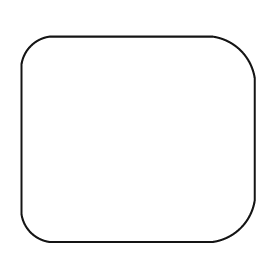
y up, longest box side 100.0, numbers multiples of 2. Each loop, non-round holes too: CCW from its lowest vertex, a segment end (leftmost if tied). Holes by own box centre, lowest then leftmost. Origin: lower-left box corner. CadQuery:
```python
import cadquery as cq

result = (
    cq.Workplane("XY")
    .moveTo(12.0, 0.0)
    .lineTo(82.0, 0.0)
    .threePointArc((94.0, 6.0), (100.0, 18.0))
    .lineTo(100.0, 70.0)
    .threePointArc((94.0, 82.0), (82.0, 88.0))
    .lineTo(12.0, 88.0)
    .threePointArc((4.0, 84.0), (0.0, 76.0))
    .lineTo(0.0, 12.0)
    .threePointArc((4.0, 4.0), (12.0, 0.0))
    .close()
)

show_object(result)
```